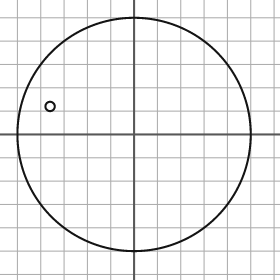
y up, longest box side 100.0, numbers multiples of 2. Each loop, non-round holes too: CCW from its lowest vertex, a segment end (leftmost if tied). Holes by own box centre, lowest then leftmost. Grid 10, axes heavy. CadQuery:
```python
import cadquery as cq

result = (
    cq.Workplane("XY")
    .moveTo(0.0, 0.0)
    .circle(50.0)
    .moveTo(-36.0, 12.0)
    .circle(2.0)
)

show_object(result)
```